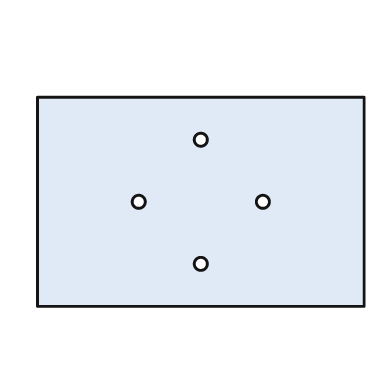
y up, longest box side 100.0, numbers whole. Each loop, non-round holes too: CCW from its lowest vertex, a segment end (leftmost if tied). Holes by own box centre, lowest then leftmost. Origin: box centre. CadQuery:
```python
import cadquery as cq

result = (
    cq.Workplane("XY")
    .moveTo(-50.0, -32.0)
    .lineTo(50.0, -32.0)
    .lineTo(50.0, 32.0)
    .lineTo(-50.0, 32.0)
    .close()
    .moveTo(0.0, -19.0)
    .circle(2.0)
    .moveTo(-19.0, 0.0)
    .circle(2.0)
    .moveTo(19.0, 0.0)
    .circle(2.0)
    .moveTo(0.0, 19.0)
    .circle(2.0)
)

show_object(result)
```